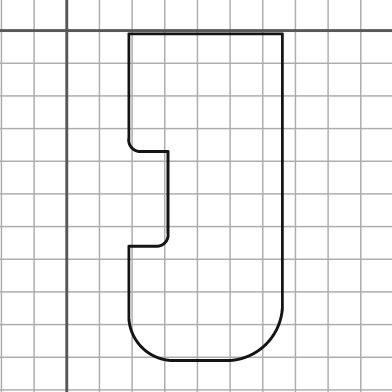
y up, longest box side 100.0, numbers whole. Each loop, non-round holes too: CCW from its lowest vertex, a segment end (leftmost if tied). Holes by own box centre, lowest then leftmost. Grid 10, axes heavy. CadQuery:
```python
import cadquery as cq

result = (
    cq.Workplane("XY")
    .moveTo(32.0, -101.0)
    .lineTo(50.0, -101.0)
    .threePointArc((61.0, -96.0), (66.0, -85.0))
    .lineTo(66.0, -1.0)
    .lineTo(19.0, -1.0)
    .lineTo(19.0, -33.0)
    .threePointArc((20.0, -36.0), (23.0, -37.0))
    .lineTo(31.0, -37.0)
    .lineTo(31.0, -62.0)
    .threePointArc((30.0, -65.0), (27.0, -66.0))
    .lineTo(19.0, -66.0)
    .lineTo(19.0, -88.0)
    .threePointArc((23.0, -97.0), (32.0, -101.0))
    .close()
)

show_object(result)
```